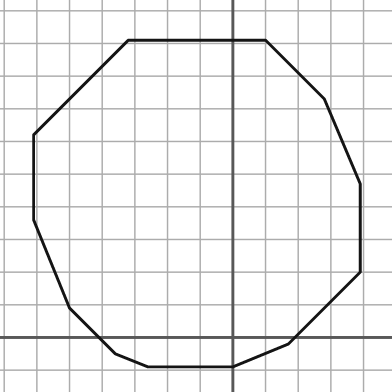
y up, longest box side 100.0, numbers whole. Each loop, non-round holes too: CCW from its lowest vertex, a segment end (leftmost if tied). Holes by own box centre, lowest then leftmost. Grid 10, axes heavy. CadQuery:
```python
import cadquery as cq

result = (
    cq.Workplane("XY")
    .moveTo(-26.0, -9.0)
    .lineTo(0.0, -9.0)
    .lineTo(17.0, -2.0)
    .lineTo(39.0, 20.0)
    .lineTo(39.0, 47.0)
    .lineTo(28.0, 73.0)
    .lineTo(10.0, 91.0)
    .lineTo(-32.0, 91.0)
    .lineTo(-61.0, 62.0)
    .lineTo(-61.0, 36.0)
    .lineTo(-50.0, 9.0)
    .lineTo(-36.0, -5.0)
    .close()
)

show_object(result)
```